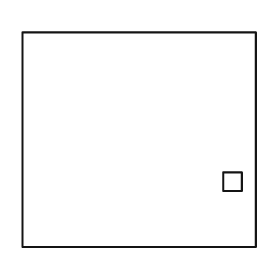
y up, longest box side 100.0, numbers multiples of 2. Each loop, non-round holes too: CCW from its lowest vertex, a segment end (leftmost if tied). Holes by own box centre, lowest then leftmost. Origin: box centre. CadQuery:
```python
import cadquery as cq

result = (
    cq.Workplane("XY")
    .moveTo(-50.0, -46.0)
    .lineTo(50.0, -46.0)
    .lineTo(50.0, 46.0)
    .lineTo(-50.0, 46.0)
    .close()
    .moveTo(36.0, -22.0)
    .lineTo(44.0, -22.0)
    .lineTo(44.0, -14.0)
    .lineTo(36.0, -14.0)
    .close()
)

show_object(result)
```